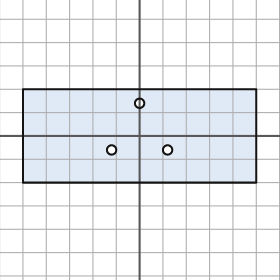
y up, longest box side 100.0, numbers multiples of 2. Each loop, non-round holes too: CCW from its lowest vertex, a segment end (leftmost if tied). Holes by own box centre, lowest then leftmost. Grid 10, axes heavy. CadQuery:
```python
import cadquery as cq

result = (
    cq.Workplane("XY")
    .moveTo(-50.0, -20.0)
    .lineTo(50.0, -20.0)
    .lineTo(50.0, 20.0)
    .lineTo(-50.0, 20.0)
    .close()
    .moveTo(-12.0, -6.0)
    .circle(2.0)
    .moveTo(12.0, -6.0)
    .circle(2.0)
    .moveTo(0.0, 14.0)
    .circle(2.0)
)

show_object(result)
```